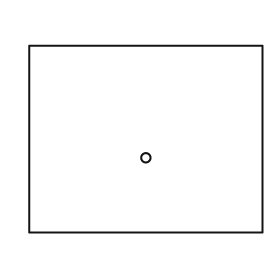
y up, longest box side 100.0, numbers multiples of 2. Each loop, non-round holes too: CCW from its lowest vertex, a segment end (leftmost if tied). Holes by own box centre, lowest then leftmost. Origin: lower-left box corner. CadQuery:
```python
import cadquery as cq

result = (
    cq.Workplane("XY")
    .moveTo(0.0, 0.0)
    .lineTo(100.0, 0.0)
    .lineTo(100.0, 80.0)
    .lineTo(0.0, 80.0)
    .close()
    .moveTo(50.0, 32.0)
    .circle(2.0)
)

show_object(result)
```